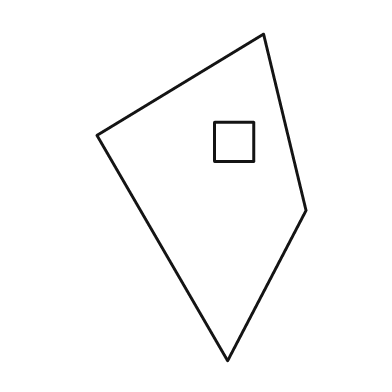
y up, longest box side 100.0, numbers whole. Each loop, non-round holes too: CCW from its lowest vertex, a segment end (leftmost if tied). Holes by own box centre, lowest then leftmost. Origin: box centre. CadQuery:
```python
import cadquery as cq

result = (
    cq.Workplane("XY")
    .moveTo(8.0, -50.0)
    .lineTo(32.0, -4.0)
    .lineTo(19.0, 50.0)
    .lineTo(-32.0, 19.0)
    .close()
    .moveTo(4.0, 11.0)
    .lineTo(16.0, 11.0)
    .lineTo(16.0, 23.0)
    .lineTo(4.0, 23.0)
    .close()
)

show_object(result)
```